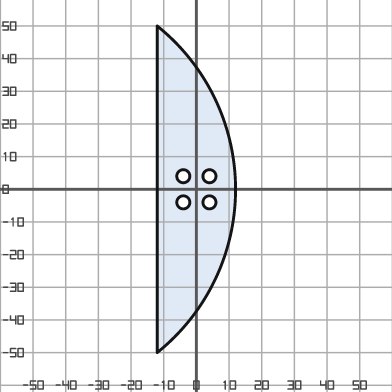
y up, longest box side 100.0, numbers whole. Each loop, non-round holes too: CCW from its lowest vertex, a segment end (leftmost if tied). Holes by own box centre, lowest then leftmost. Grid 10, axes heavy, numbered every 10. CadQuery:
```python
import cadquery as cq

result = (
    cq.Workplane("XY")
    .moveTo(-12.0, -50.0)
    .threePointArc((12.0, 0.0), (-12.0, 50.0))
    .close()
    .moveTo(-4.0, -4.0)
    .circle(2.0)
    .moveTo(4.0, -4.0)
    .circle(2.0)
    .moveTo(-4.0, 4.0)
    .circle(2.0)
    .moveTo(4.0, 4.0)
    .circle(2.0)
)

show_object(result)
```